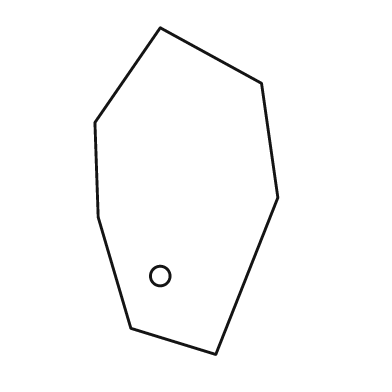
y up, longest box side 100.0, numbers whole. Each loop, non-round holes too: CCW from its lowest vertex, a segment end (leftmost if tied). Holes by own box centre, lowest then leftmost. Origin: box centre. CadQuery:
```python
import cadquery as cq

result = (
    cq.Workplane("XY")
    .moveTo(9.0, -50.0)
    .lineTo(28.0, -2.0)
    .lineTo(23.0, 33.0)
    .lineTo(-8.0, 50.0)
    .lineTo(-28.0, 21.0)
    .lineTo(-27.0, -8.0)
    .lineTo(-17.0, -42.0)
    .close()
    .moveTo(-8.0, -26.0)
    .circle(3.0)
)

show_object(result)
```